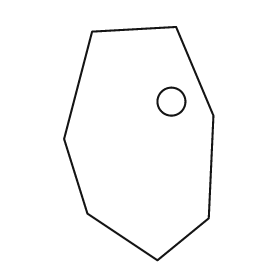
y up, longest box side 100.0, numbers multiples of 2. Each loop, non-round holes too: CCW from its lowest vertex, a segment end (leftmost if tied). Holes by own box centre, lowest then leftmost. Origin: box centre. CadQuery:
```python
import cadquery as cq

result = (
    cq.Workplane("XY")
    .moveTo(8.0, -50.0)
    .lineTo(30.0, -32.0)
    .lineTo(32.0, 12.0)
    .lineTo(16.0, 50.0)
    .lineTo(-20.0, 48.0)
    .lineTo(-32.0, 2.0)
    .lineTo(-22.0, -30.0)
    .close()
    .moveTo(14.0, 18.0)
    .circle(6.0)
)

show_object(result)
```